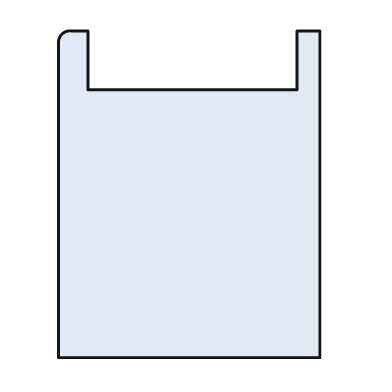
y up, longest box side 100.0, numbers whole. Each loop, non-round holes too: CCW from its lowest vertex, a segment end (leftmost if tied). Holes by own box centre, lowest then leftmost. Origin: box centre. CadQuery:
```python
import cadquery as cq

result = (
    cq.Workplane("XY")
    .moveTo(-40.0, -50.0)
    .lineTo(40.0, -50.0)
    .lineTo(40.0, 50.0)
    .lineTo(33.0, 50.0)
    .lineTo(33.0, 32.0)
    .lineTo(-31.0, 32.0)
    .lineTo(-31.0, 50.0)
    .lineTo(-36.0, 50.0)
    .threePointArc((-39.0, 49.0), (-40.0, 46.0))
    .close()
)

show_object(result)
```